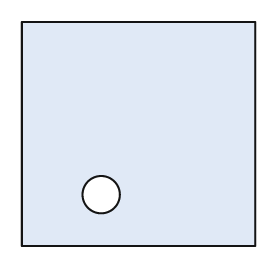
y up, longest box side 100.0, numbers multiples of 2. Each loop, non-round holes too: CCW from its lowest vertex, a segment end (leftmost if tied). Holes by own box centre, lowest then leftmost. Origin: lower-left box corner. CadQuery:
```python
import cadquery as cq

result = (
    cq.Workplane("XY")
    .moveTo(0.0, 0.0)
    .lineTo(100.0, 0.0)
    .lineTo(100.0, 96.0)
    .lineTo(0.0, 96.0)
    .close()
    .moveTo(34.0, 22.0)
    .circle(8.0)
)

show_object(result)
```